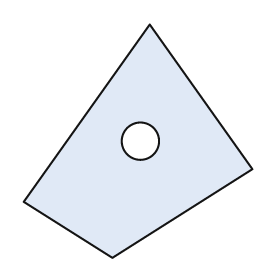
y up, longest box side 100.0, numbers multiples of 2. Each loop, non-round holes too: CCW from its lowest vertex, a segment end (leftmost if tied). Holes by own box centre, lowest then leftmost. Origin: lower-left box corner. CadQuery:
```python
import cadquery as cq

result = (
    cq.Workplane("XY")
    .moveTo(38.0, 0.0)
    .lineTo(98.0, 38.0)
    .lineTo(54.0, 100.0)
    .lineTo(0.0, 24.0)
    .close()
    .moveTo(50.0, 50.0)
    .circle(8.0)
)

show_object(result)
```